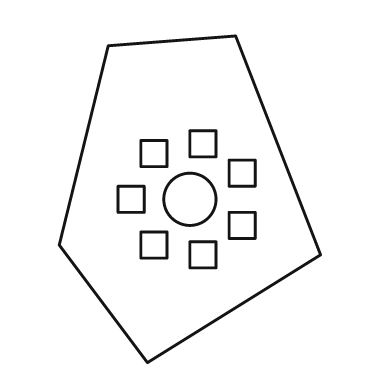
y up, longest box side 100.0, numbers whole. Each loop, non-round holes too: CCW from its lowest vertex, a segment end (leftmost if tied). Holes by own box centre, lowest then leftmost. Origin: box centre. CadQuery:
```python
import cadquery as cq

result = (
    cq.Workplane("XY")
    .moveTo(-13.0, -50.0)
    .lineTo(40.0, -17.0)
    .lineTo(14.0, 50.0)
    .lineTo(-25.0, 47.0)
    .lineTo(-40.0, -14.0)
    .close()
    .moveTo(0.0, -21.0)
    .lineTo(8.0, -21.0)
    .lineTo(8.0, -13.0)
    .lineTo(0.0, -13.0)
    .close()
    .moveTo(-15.0, -18.0)
    .lineTo(-7.0, -18.0)
    .lineTo(-7.0, -10.0)
    .lineTo(-15.0, -10.0)
    .close()
    .moveTo(12.0, -12.0)
    .lineTo(20.0, -12.0)
    .lineTo(20.0, -4.0)
    .lineTo(12.0, -4.0)
    .close()
    .moveTo(-22.0, -4.0)
    .lineTo(-14.0, -4.0)
    .lineTo(-14.0, 4.0)
    .lineTo(-22.0, 4.0)
    .close()
    .moveTo(0.0, 0.0)
    .circle(8.0)
    .moveTo(12.0, 4.0)
    .lineTo(20.0, 4.0)
    .lineTo(20.0, 12.0)
    .lineTo(12.0, 12.0)
    .close()
    .moveTo(-15.0, 10.0)
    .lineTo(-7.0, 10.0)
    .lineTo(-7.0, 18.0)
    .lineTo(-15.0, 18.0)
    .close()
    .moveTo(0.0, 13.0)
    .lineTo(8.0, 13.0)
    .lineTo(8.0, 21.0)
    .lineTo(0.0, 21.0)
    .close()
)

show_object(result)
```